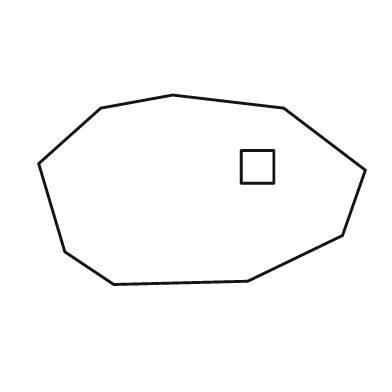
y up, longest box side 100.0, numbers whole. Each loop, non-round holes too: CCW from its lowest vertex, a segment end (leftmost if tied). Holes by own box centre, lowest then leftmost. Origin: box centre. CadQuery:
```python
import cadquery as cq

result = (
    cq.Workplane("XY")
    .moveTo(-27.0, -29.0)
    .lineTo(14.0, -28.0)
    .lineTo(43.0, -14.0)
    .lineTo(50.0, 6.0)
    .lineTo(25.0, 25.0)
    .lineTo(-9.0, 29.0)
    .lineTo(-31.0, 25.0)
    .lineTo(-50.0, 8.0)
    .lineTo(-42.0, -19.0)
    .close()
    .moveTo(12.0, 2.0)
    .lineTo(22.0, 2.0)
    .lineTo(22.0, 12.0)
    .lineTo(12.0, 12.0)
    .close()
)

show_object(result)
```